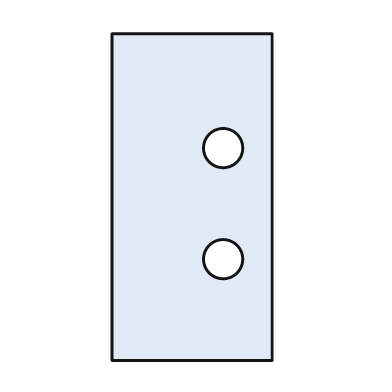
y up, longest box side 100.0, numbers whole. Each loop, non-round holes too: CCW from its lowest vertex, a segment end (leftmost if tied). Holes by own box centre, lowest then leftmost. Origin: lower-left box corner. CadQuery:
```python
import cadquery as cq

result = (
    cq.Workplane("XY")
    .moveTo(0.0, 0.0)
    .lineTo(49.0, 0.0)
    .lineTo(49.0, 100.0)
    .lineTo(0.0, 100.0)
    .close()
    .moveTo(34.0, 31.0)
    .circle(6.0)
    .moveTo(34.0, 65.0)
    .circle(6.0)
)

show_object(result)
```